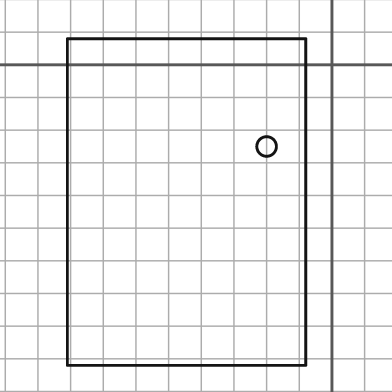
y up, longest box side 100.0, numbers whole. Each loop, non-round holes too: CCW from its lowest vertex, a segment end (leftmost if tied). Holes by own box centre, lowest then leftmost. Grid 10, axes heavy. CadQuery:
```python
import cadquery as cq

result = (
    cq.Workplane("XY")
    .moveTo(-81.0, -92.0)
    .lineTo(-8.0, -92.0)
    .lineTo(-8.0, 8.0)
    .lineTo(-81.0, 8.0)
    .close()
    .moveTo(-20.0, -25.0)
    .circle(3.0)
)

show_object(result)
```